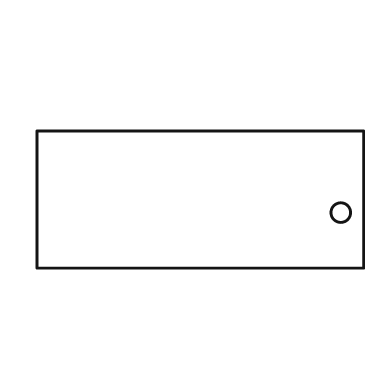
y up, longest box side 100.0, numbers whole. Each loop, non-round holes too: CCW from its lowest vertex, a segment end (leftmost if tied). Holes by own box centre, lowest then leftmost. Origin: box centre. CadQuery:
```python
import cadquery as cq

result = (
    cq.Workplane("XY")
    .moveTo(-50.0, -21.0)
    .lineTo(50.0, -21.0)
    .lineTo(50.0, 21.0)
    .lineTo(-50.0, 21.0)
    .close()
    .moveTo(43.0, -4.0)
    .circle(3.0)
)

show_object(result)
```